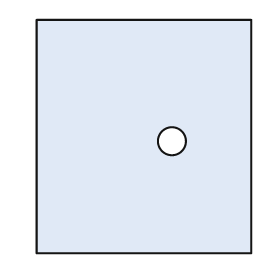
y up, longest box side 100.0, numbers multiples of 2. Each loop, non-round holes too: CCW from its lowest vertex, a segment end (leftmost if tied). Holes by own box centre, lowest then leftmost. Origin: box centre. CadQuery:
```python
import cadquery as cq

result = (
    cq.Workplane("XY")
    .moveTo(-46.0, -50.0)
    .lineTo(46.0, -50.0)
    .lineTo(46.0, 50.0)
    .lineTo(-46.0, 50.0)
    .close()
    .moveTo(12.0, -2.0)
    .circle(6.0)
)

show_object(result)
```